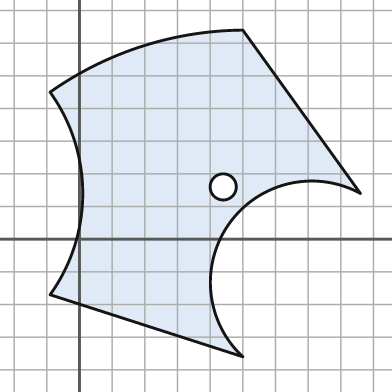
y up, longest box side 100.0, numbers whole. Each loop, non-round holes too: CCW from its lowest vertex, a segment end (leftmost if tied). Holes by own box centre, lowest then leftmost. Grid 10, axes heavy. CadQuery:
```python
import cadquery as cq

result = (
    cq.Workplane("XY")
    .moveTo(50.0, -36.0)
    .threePointArc((46.0, 5.0), (86.0, 14.0))
    .lineTo(50.0, 64.0)
    .threePointArc((19.0, 59.0), (-9.0, 45.0))
    .threePointArc((1.0, 14.0), (-9.0, -17.0))
    .close()
    .moveTo(44.0, 16.0)
    .circle(4.0)
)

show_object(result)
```